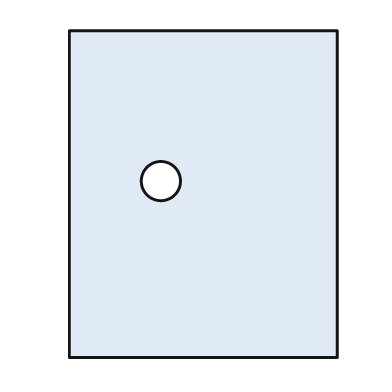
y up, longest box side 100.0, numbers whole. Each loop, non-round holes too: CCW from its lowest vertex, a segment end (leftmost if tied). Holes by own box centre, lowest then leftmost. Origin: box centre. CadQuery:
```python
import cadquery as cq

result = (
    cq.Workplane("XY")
    .moveTo(-41.0, -50.0)
    .lineTo(41.0, -50.0)
    .lineTo(41.0, 50.0)
    .lineTo(-41.0, 50.0)
    .close()
    .moveTo(-13.0, 4.0)
    .circle(6.0)
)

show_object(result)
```